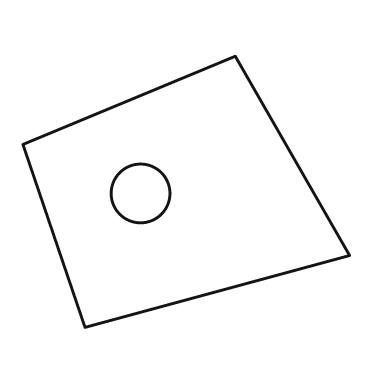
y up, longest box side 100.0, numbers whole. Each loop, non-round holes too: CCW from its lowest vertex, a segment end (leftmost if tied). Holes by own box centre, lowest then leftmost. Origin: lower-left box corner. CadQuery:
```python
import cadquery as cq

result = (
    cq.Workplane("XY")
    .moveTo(19.0, 0.0)
    .lineTo(100.0, 22.0)
    .lineTo(65.0, 83.0)
    .lineTo(0.0, 56.0)
    .close()
    .moveTo(36.0, 41.0)
    .circle(9.0)
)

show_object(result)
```